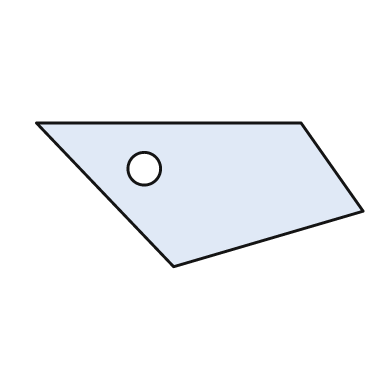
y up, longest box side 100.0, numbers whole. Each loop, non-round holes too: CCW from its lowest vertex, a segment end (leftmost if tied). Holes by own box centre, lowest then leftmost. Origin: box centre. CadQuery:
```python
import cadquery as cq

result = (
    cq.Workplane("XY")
    .moveTo(-8.0, -22.0)
    .lineTo(50.0, -5.0)
    .lineTo(31.0, 22.0)
    .lineTo(-50.0, 22.0)
    .close()
    .moveTo(-17.0, 8.0)
    .circle(5.0)
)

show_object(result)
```